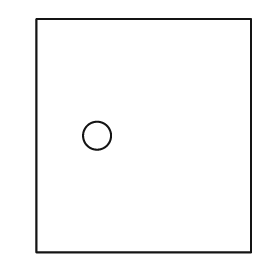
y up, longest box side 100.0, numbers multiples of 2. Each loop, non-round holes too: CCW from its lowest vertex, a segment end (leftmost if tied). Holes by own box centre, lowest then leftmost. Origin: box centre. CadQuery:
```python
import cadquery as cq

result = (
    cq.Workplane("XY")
    .moveTo(-46.0, -50.0)
    .lineTo(46.0, -50.0)
    .lineTo(46.0, 50.0)
    .lineTo(-46.0, 50.0)
    .close()
    .moveTo(-20.0, 0.0)
    .circle(6.0)
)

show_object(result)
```